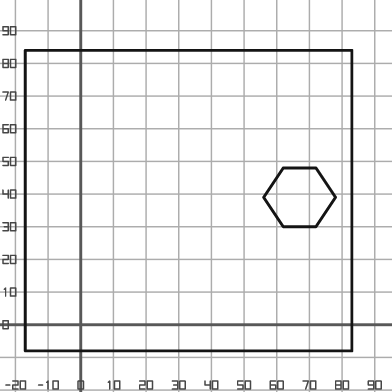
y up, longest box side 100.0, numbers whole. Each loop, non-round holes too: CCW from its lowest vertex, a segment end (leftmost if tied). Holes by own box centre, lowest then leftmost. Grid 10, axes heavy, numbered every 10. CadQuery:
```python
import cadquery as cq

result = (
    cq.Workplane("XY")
    .moveTo(-17.0, -8.0)
    .lineTo(83.0, -8.0)
    .lineTo(83.0, 84.0)
    .lineTo(-17.0, 84.0)
    .close()
    .moveTo(62.0, 30.0)
    .lineTo(72.0, 30.0)
    .lineTo(78.0, 39.0)
    .lineTo(72.0, 48.0)
    .lineTo(62.0, 48.0)
    .lineTo(56.0, 39.0)
    .close()
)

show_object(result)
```